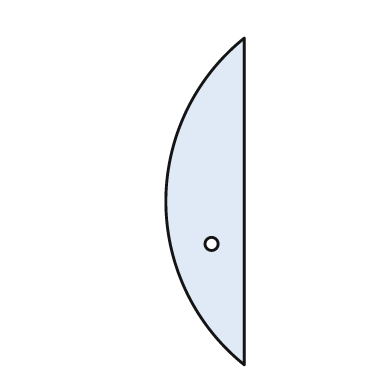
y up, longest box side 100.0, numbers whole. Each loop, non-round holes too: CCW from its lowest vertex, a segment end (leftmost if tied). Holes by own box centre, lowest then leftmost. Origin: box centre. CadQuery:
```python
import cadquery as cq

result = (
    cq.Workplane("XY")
    .moveTo(12.0, -50.0)
    .lineTo(12.0, 50.0)
    .threePointArc((-12.0, 0.0), (12.0, -50.0))
    .close()
    .moveTo(2.0, -13.0)
    .circle(2.0)
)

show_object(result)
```